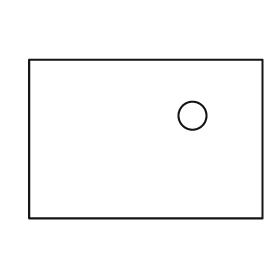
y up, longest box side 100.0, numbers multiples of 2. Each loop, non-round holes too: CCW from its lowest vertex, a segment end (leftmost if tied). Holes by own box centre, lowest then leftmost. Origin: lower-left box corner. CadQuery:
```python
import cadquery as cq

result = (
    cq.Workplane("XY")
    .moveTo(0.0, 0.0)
    .lineTo(100.0, 0.0)
    .lineTo(100.0, 68.0)
    .lineTo(0.0, 68.0)
    .close()
    .moveTo(70.0, 44.0)
    .circle(6.0)
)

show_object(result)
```